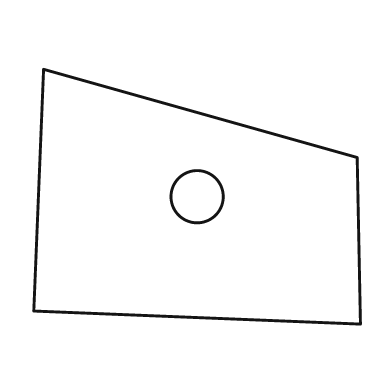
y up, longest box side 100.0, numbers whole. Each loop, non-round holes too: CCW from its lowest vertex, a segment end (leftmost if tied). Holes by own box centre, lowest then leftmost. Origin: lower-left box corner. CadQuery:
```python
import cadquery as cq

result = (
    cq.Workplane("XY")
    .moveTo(100.0, 0.0)
    .lineTo(99.0, 51.0)
    .lineTo(3.0, 78.0)
    .lineTo(0.0, 4.0)
    .close()
    .moveTo(50.0, 39.0)
    .circle(8.0)
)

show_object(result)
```